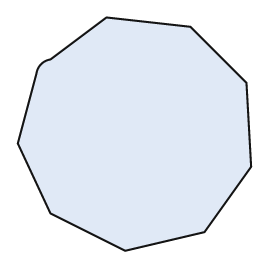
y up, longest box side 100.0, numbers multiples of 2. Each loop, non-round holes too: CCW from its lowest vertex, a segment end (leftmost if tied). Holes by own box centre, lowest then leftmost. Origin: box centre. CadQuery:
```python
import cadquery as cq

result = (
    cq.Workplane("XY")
    .moveTo(-4.0, -50.0)
    .lineTo(30.0, -42.0)
    .lineTo(50.0, -14.0)
    .lineTo(48.0, 22.0)
    .lineTo(24.0, 46.0)
    .lineTo(-12.0, 50.0)
    .lineTo(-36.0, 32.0)
    .threePointArc((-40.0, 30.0), (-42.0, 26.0))
    .lineTo(-50.0, -4.0)
    .lineTo(-36.0, -34.0)
    .close()
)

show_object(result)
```